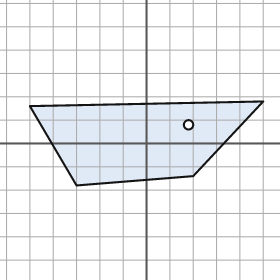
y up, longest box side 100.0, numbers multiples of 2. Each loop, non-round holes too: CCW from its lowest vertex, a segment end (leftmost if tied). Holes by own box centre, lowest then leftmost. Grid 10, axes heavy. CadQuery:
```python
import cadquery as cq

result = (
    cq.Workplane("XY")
    .moveTo(-30.0, -18.0)
    .lineTo(20.0, -14.0)
    .lineTo(50.0, 18.0)
    .lineTo(-50.0, 16.0)
    .close()
    .moveTo(18.0, 8.0)
    .circle(2.0)
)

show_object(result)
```